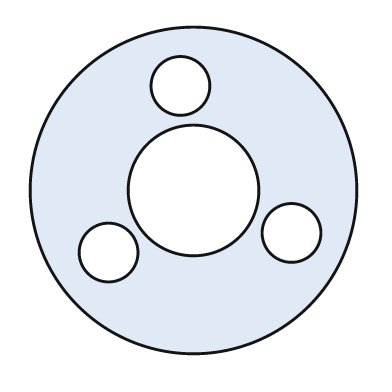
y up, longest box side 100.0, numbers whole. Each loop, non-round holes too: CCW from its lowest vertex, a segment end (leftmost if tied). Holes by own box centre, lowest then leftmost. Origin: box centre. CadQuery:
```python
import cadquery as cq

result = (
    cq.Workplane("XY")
    .moveTo(0.0, 0.0)
    .circle(50.0)
    .moveTo(-26.0, -19.0)
    .circle(9.0)
    .moveTo(30.0, -13.0)
    .circle(9.0)
    .moveTo(0.0, 0.0)
    .circle(20.0)
    .moveTo(-4.0, 32.0)
    .circle(9.0)
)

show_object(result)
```